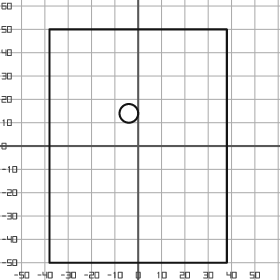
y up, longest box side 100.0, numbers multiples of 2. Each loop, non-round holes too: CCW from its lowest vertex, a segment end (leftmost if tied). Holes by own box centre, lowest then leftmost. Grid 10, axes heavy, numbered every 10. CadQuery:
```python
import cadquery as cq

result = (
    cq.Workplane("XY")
    .moveTo(-38.0, -50.0)
    .lineTo(38.0, -50.0)
    .lineTo(38.0, 50.0)
    .lineTo(-38.0, 50.0)
    .close()
    .moveTo(-4.0, 14.0)
    .circle(4.0)
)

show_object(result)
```